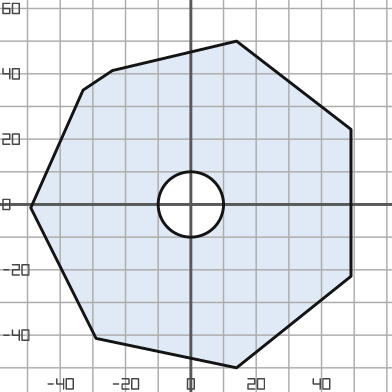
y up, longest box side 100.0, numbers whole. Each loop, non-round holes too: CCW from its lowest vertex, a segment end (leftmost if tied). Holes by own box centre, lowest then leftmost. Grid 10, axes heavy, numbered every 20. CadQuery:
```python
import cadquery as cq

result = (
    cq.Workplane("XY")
    .moveTo(14.0, -50.0)
    .lineTo(49.0, -22.0)
    .lineTo(49.0, 23.0)
    .lineTo(14.0, 50.0)
    .lineTo(-24.0, 41.0)
    .lineTo(-33.0, 35.0)
    .lineTo(-49.0, -1.0)
    .lineTo(-29.0, -41.0)
    .close()
    .moveTo(0.0, 0.0)
    .circle(10.0)
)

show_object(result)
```